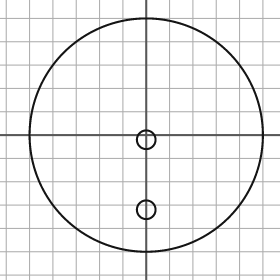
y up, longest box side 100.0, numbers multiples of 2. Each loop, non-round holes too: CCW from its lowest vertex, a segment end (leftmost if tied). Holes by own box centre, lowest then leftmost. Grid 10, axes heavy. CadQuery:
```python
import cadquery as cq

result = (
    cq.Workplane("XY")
    .moveTo(0.0, 0.0)
    .circle(50.0)
    .moveTo(0.0, -32.0)
    .circle(4.0)
    .moveTo(0.0, -2.0)
    .circle(4.0)
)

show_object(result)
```